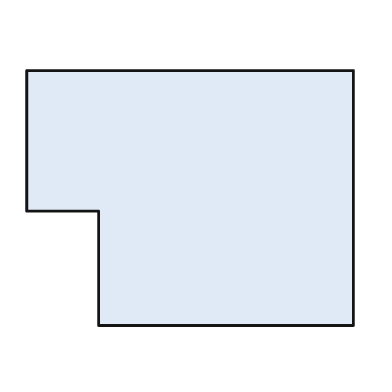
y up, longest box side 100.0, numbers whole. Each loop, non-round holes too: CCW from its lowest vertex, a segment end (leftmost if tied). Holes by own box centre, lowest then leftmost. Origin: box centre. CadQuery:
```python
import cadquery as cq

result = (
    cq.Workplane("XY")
    .moveTo(-28.0, -39.0)
    .lineTo(50.0, -39.0)
    .lineTo(50.0, 39.0)
    .lineTo(-50.0, 39.0)
    .lineTo(-50.0, -4.0)
    .lineTo(-28.0, -4.0)
    .close()
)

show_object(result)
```